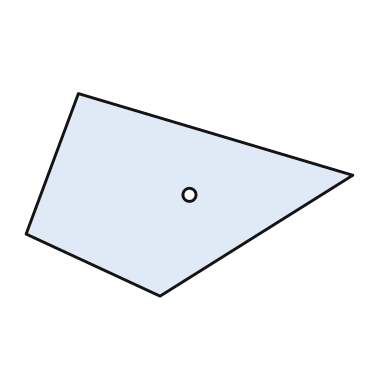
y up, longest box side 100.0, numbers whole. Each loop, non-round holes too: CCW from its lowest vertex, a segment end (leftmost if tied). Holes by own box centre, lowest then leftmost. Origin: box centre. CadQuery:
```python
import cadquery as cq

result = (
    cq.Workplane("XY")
    .moveTo(-9.0, -31.0)
    .lineTo(50.0, 6.0)
    .lineTo(-34.0, 31.0)
    .lineTo(-50.0, -12.0)
    .close()
    .moveTo(0.0, 0.0)
    .circle(2.0)
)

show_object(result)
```